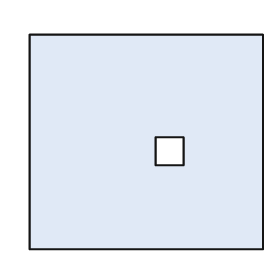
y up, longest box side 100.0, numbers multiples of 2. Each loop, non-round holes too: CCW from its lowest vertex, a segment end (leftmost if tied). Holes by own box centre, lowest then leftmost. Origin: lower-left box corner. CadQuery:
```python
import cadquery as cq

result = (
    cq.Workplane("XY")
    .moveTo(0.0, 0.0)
    .lineTo(100.0, 0.0)
    .lineTo(100.0, 92.0)
    .lineTo(0.0, 92.0)
    .close()
    .moveTo(54.0, 36.0)
    .lineTo(66.0, 36.0)
    .lineTo(66.0, 48.0)
    .lineTo(54.0, 48.0)
    .close()
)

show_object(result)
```